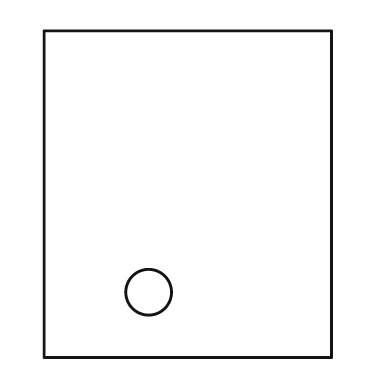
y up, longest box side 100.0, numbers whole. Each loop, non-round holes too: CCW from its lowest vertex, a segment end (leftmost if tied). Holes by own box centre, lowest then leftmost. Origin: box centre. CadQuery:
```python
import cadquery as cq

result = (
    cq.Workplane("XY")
    .moveTo(-44.0, -50.0)
    .lineTo(44.0, -50.0)
    .lineTo(44.0, 50.0)
    .lineTo(-44.0, 50.0)
    .close()
    .moveTo(-12.0, -30.0)
    .circle(7.0)
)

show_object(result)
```